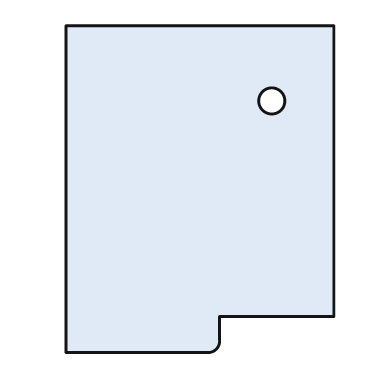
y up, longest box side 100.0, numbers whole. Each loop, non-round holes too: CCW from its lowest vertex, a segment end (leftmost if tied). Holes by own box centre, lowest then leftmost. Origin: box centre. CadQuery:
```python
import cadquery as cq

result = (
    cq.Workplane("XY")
    .moveTo(-41.0, -50.0)
    .lineTo(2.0, -50.0)
    .threePointArc((5.0, -49.0), (6.0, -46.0))
    .lineTo(6.0, -39.0)
    .lineTo(41.0, -39.0)
    .lineTo(41.0, 50.0)
    .lineTo(-41.0, 50.0)
    .close()
    .moveTo(22.0, 27.0)
    .circle(4.0)
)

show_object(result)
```